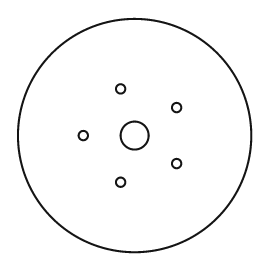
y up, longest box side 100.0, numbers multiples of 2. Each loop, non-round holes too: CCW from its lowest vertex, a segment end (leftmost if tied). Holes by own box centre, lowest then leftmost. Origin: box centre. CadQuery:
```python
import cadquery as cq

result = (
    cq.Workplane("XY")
    .moveTo(0.0, 0.0)
    .circle(50.0)
    .moveTo(-6.0, -20.0)
    .circle(2.0)
    .moveTo(18.0, -12.0)
    .circle(2.0)
    .moveTo(-22.0, 0.0)
    .circle(2.0)
    .moveTo(0.0, 0.0)
    .circle(6.0)
    .moveTo(18.0, 12.0)
    .circle(2.0)
    .moveTo(-6.0, 20.0)
    .circle(2.0)
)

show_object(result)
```